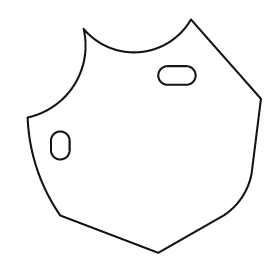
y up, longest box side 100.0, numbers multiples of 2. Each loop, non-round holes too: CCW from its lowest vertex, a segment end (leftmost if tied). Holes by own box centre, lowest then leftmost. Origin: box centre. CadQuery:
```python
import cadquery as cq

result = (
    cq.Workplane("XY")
    .moveTo(6.0, -50.0)
    .lineTo(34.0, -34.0)
    .threePointArc((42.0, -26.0), (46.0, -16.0))
    .lineTo(50.0, 16.0)
    .lineTo(20.0, 50.0)
    .threePointArc((-2.0, 36.0), (-26.0, 46.0))
    .threePointArc((-30.0, 22.0), (-50.0, 8.0))
    .threePointArc((-46.0, -14.0), (-36.0, -34.0))
    .close()
    .moveTo(-40.0, -6.0)
    .threePointArc((-36.0, -10.0), (-32.0, -6.0))
    .lineTo(-32.0, -2.0)
    .threePointArc((-36.0, 2.0), (-40.0, -2.0))
    .close()
    .moveTo(10.0, 22.0)
    .lineTo(18.0, 22.0)
    .threePointArc((22.0, 26.0), (18.0, 30.0))
    .lineTo(10.0, 30.0)
    .threePointArc((6.0, 26.0), (10.0, 22.0))
    .close()
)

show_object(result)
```